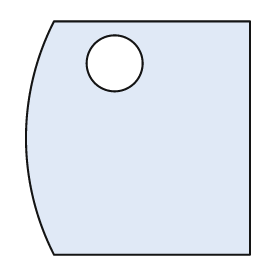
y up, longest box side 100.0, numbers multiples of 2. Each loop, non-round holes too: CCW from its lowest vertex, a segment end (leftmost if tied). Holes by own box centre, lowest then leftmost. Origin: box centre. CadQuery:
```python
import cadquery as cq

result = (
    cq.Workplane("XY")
    .moveTo(-36.0, -50.0)
    .lineTo(48.0, -50.0)
    .lineTo(48.0, 50.0)
    .lineTo(-36.0, 50.0)
    .threePointArc((-48.0, 0.0), (-36.0, -50.0))
    .close()
    .moveTo(-10.0, 32.0)
    .circle(12.0)
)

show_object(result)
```